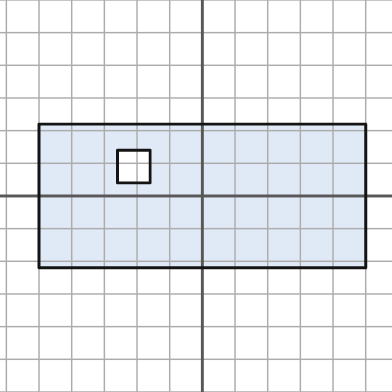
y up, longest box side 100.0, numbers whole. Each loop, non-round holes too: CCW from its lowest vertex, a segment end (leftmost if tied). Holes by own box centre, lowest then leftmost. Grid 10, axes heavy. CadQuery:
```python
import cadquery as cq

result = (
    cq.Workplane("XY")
    .moveTo(-50.0, -22.0)
    .lineTo(50.0, -22.0)
    .lineTo(50.0, 22.0)
    .lineTo(-50.0, 22.0)
    .close()
    .moveTo(-26.0, 4.0)
    .lineTo(-16.0, 4.0)
    .lineTo(-16.0, 14.0)
    .lineTo(-26.0, 14.0)
    .close()
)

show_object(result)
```